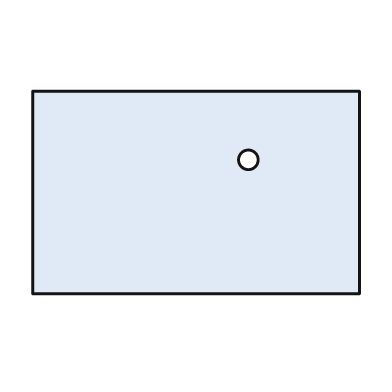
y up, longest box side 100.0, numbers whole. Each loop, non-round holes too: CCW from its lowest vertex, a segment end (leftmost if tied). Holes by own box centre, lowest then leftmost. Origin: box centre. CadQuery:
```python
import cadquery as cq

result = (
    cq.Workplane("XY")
    .moveTo(-50.0, -31.0)
    .lineTo(50.0, -31.0)
    .lineTo(50.0, 31.0)
    .lineTo(-50.0, 31.0)
    .close()
    .moveTo(16.0, 10.0)
    .circle(3.0)
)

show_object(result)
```